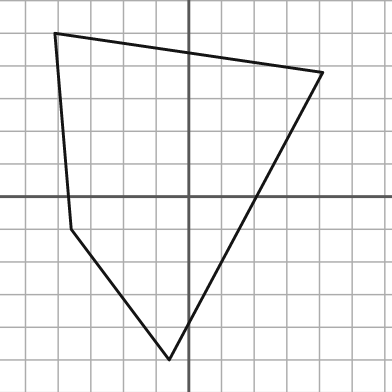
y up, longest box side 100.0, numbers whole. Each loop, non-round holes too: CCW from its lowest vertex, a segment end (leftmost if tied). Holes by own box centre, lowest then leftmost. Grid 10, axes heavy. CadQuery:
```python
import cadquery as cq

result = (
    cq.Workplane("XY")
    .moveTo(-6.0, -50.0)
    .lineTo(41.0, 38.0)
    .lineTo(-41.0, 50.0)
    .lineTo(-36.0, -10.0)
    .close()
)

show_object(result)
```